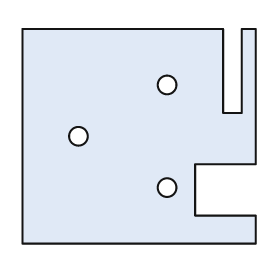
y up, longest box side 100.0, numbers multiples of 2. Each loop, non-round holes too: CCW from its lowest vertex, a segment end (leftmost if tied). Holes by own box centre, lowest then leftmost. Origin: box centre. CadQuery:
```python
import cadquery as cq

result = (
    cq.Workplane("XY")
    .moveTo(-50.0, -46.0)
    .lineTo(50.0, -46.0)
    .lineTo(50.0, -34.0)
    .lineTo(24.0, -34.0)
    .lineTo(24.0, -12.0)
    .lineTo(50.0, -12.0)
    .lineTo(50.0, 46.0)
    .lineTo(44.0, 46.0)
    .lineTo(44.0, 10.0)
    .lineTo(36.0, 10.0)
    .lineTo(36.0, 46.0)
    .lineTo(-50.0, 46.0)
    .close()
    .moveTo(12.0, -22.0)
    .circle(4.0)
    .moveTo(-26.0, 0.0)
    .circle(4.0)
    .moveTo(12.0, 22.0)
    .circle(4.0)
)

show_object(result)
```